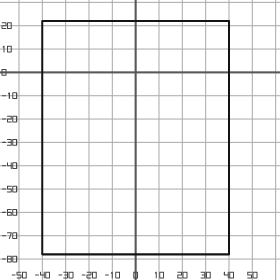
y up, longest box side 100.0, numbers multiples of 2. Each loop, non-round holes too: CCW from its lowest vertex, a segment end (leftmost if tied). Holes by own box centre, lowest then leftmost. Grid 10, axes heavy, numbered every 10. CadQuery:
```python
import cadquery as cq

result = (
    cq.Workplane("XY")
    .moveTo(-40.0, -78.0)
    .lineTo(40.0, -78.0)
    .lineTo(40.0, 22.0)
    .lineTo(-40.0, 22.0)
    .close()
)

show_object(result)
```